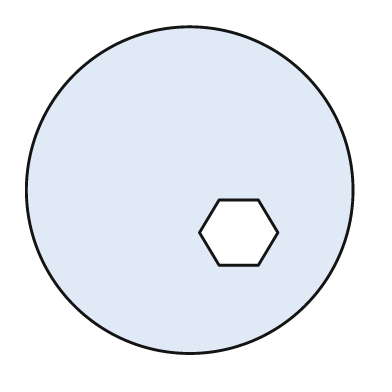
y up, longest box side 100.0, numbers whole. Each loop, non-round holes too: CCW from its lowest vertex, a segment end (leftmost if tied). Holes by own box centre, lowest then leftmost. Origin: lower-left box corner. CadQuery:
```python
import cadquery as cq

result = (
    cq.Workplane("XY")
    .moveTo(50.0, 50.0)
    .circle(50.0)
    .moveTo(59.0, 27.0)
    .lineTo(71.0, 27.0)
    .lineTo(77.0, 37.0)
    .lineTo(71.0, 47.0)
    .lineTo(59.0, 47.0)
    .lineTo(53.0, 37.0)
    .close()
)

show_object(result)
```